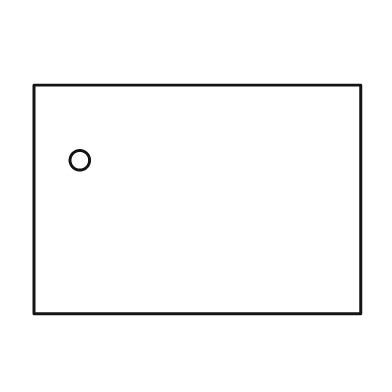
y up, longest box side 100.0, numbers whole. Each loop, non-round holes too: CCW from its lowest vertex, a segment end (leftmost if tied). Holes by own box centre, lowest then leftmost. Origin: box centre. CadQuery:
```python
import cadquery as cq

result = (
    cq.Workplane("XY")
    .moveTo(-50.0, -35.0)
    .lineTo(50.0, -35.0)
    .lineTo(50.0, 35.0)
    .lineTo(-50.0, 35.0)
    .close()
    .moveTo(-36.0, 12.0)
    .circle(3.0)
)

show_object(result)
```